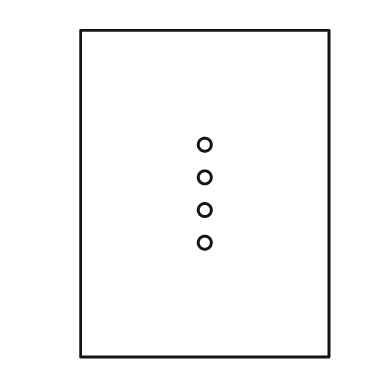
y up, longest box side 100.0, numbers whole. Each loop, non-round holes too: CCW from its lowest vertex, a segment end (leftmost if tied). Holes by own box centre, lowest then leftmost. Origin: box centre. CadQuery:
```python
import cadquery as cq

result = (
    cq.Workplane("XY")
    .moveTo(-38.0, -50.0)
    .lineTo(38.0, -50.0)
    .lineTo(38.0, 50.0)
    .lineTo(-38.0, 50.0)
    .close()
    .moveTo(0.0, -15.0)
    .circle(2.0)
    .moveTo(0.0, -5.0)
    .circle(2.0)
    .moveTo(0.0, 5.0)
    .circle(2.0)
    .moveTo(0.0, 15.0)
    .circle(2.0)
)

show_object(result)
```